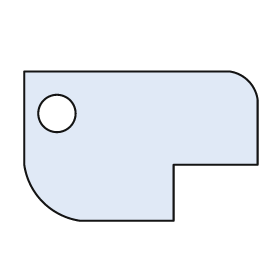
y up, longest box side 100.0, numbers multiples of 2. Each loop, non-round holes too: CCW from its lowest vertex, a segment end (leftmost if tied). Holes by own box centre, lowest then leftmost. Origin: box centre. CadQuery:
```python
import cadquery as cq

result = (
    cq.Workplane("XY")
    .moveTo(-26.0, -32.0)
    .lineTo(14.0, -32.0)
    .lineTo(14.0, -8.0)
    .lineTo(50.0, -8.0)
    .lineTo(50.0, 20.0)
    .threePointArc((46.0, 28.0), (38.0, 32.0))
    .lineTo(-50.0, 32.0)
    .lineTo(-50.0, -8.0)
    .threePointArc((-42.0, -24.0), (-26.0, -32.0))
    .close()
    .moveTo(-36.0, 14.0)
    .circle(8.0)
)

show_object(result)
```